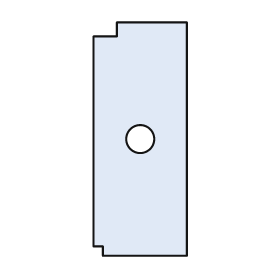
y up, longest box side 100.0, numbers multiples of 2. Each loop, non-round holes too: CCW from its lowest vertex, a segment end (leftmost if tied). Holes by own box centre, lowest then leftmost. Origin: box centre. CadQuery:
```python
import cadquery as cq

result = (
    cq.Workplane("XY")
    .moveTo(-16.0, -50.0)
    .lineTo(20.0, -50.0)
    .lineTo(20.0, 50.0)
    .lineTo(-10.0, 50.0)
    .lineTo(-10.0, 44.0)
    .lineTo(-20.0, 44.0)
    .lineTo(-20.0, -46.0)
    .lineTo(-16.0, -46.0)
    .close()
    .moveTo(0.0, 0.0)
    .circle(6.0)
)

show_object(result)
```